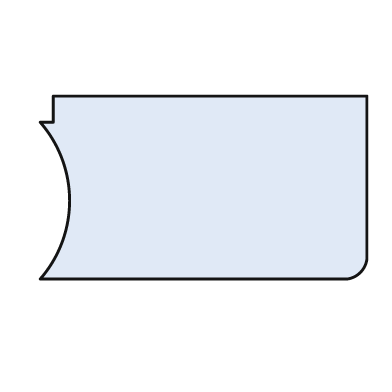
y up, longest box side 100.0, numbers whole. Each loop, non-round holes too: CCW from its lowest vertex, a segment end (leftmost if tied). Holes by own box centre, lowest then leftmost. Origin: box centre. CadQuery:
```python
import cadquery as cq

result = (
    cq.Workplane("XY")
    .moveTo(-50.0, -28.0)
    .lineTo(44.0, -28.0)
    .threePointArc((48.0, -26.0), (50.0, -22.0))
    .lineTo(50.0, 28.0)
    .lineTo(-46.0, 28.0)
    .lineTo(-46.0, 20.0)
    .lineTo(-50.0, 20.0)
    .threePointArc((-41.0, -4.0), (-50.0, -28.0))
    .close()
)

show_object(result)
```